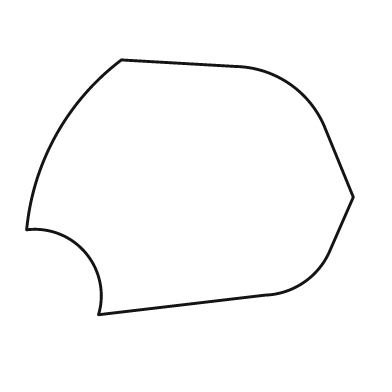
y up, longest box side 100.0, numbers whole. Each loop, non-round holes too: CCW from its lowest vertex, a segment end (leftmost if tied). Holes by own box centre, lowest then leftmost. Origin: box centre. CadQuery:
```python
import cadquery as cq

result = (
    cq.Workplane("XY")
    .moveTo(-28.0, -39.0)
    .lineTo(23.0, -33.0)
    .threePointArc((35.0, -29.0), (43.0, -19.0))
    .lineTo(50.0, -3.0)
    .lineTo(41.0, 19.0)
    .threePointArc((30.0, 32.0), (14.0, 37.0))
    .lineTo(-21.0, 39.0)
    .threePointArc((-41.0, 16.0), (-50.0, -13.0))
    .threePointArc((-32.0, -20.0), (-28.0, -39.0))
    .close()
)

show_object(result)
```